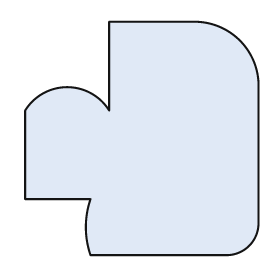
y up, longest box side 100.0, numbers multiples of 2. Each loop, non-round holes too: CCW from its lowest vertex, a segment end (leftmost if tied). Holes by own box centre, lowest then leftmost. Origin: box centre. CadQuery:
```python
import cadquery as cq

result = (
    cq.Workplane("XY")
    .moveTo(-22.0, -50.0)
    .lineTo(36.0, -50.0)
    .threePointArc((46.0, -46.0), (50.0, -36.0))
    .lineTo(50.0, 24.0)
    .threePointArc((42.0, 42.0), (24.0, 50.0))
    .lineTo(-14.0, 50.0)
    .lineTo(-14.0, 12.0)
    .threePointArc((-32.0, 22.0), (-50.0, 12.0))
    .lineTo(-50.0, -26.0)
    .lineTo(-22.0, -26.0)
    .threePointArc((-24.0, -38.0), (-22.0, -50.0))
    .close()
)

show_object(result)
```